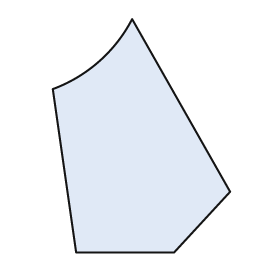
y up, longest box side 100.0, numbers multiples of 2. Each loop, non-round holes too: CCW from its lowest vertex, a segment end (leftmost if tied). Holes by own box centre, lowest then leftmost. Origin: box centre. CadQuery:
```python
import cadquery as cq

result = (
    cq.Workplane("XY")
    .moveTo(-28.0, -50.0)
    .lineTo(14.0, -50.0)
    .lineTo(38.0, -24.0)
    .lineTo(-4.0, 50.0)
    .threePointArc((-18.0, 32.0), (-38.0, 20.0))
    .close()
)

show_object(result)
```